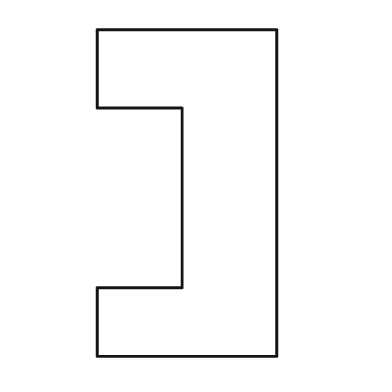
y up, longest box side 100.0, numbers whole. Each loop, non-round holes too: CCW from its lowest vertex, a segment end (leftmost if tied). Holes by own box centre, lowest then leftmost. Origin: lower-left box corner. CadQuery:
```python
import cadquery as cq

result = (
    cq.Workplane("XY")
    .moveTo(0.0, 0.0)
    .lineTo(55.0, 0.0)
    .lineTo(55.0, 100.0)
    .lineTo(0.0, 100.0)
    .lineTo(0.0, 76.0)
    .lineTo(26.0, 76.0)
    .lineTo(26.0, 21.0)
    .lineTo(0.0, 21.0)
    .close()
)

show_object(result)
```